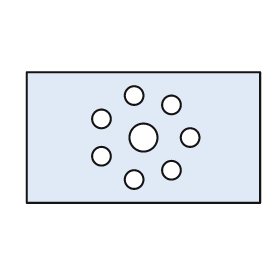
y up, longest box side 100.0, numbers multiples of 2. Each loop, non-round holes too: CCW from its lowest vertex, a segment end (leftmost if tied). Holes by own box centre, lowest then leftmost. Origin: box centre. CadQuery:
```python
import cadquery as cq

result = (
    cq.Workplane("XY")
    .moveTo(-50.0, -28.0)
    .lineTo(50.0, -28.0)
    .lineTo(50.0, 28.0)
    .lineTo(-50.0, 28.0)
    .close()
    .moveTo(-4.0, -18.0)
    .circle(4.0)
    .moveTo(12.0, -14.0)
    .circle(4.0)
    .moveTo(-18.0, -8.0)
    .circle(4.0)
    .moveTo(0.0, 0.0)
    .circle(6.0)
    .moveTo(20.0, 0.0)
    .circle(4.0)
    .moveTo(-18.0, 8.0)
    .circle(4.0)
    .moveTo(12.0, 14.0)
    .circle(4.0)
    .moveTo(-4.0, 18.0)
    .circle(4.0)
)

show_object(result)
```